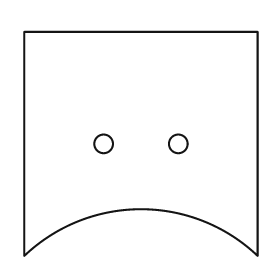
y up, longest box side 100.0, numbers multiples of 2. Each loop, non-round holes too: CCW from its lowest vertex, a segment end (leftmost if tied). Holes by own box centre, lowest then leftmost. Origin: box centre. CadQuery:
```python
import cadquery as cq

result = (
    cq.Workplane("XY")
    .moveTo(-50.0, -48.0)
    .threePointArc((0.0, -28.0), (50.0, -48.0))
    .lineTo(50.0, 48.0)
    .lineTo(-50.0, 48.0)
    .close()
    .moveTo(-16.0, 0.0)
    .circle(4.0)
    .moveTo(16.0, 0.0)
    .circle(4.0)
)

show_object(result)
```